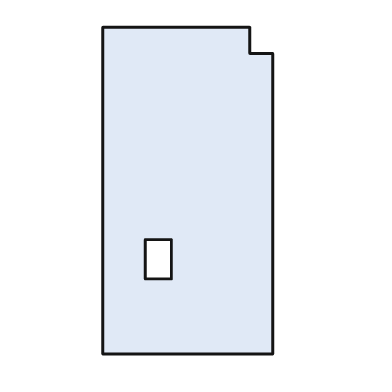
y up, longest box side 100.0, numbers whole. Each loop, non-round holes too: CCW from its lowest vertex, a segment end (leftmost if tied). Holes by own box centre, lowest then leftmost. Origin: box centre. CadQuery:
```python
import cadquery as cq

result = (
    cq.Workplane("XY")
    .moveTo(-26.0, -50.0)
    .lineTo(26.0, -50.0)
    .lineTo(26.0, 42.0)
    .lineTo(19.0, 42.0)
    .lineTo(19.0, 50.0)
    .lineTo(-26.0, 50.0)
    .close()
    .moveTo(-13.0, -27.0)
    .lineTo(-5.0, -27.0)
    .lineTo(-5.0, -15.0)
    .lineTo(-13.0, -15.0)
    .close()
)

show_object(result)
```